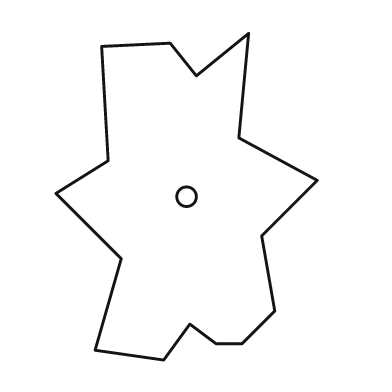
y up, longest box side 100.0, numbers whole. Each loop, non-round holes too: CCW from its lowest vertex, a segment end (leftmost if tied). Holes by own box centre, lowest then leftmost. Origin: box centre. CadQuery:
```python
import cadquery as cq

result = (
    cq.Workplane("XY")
    .moveTo(-7.0, -50.0)
    .lineTo(1.0, -39.0)
    .lineTo(9.0, -45.0)
    .lineTo(17.0, -45.0)
    .lineTo(27.0, -35.0)
    .lineTo(23.0, -12.0)
    .lineTo(40.0, 5.0)
    .lineTo(16.0, 18.0)
    .lineTo(19.0, 50.0)
    .lineTo(3.0, 37.0)
    .lineTo(-5.0, 47.0)
    .lineTo(-26.0, 46.0)
    .lineTo(-24.0, 11.0)
    .lineTo(-40.0, 1.0)
    .lineTo(-20.0, -19.0)
    .lineTo(-28.0, -47.0)
    .close()
    .moveTo(0.0, 0.0)
    .circle(3.0)
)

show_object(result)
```